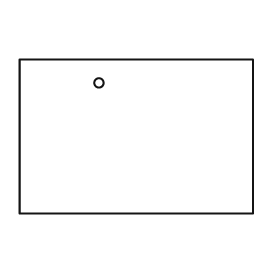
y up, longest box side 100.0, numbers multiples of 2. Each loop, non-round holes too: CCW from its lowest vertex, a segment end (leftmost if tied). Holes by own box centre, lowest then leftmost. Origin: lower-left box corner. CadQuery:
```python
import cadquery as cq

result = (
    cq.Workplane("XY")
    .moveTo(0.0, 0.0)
    .lineTo(100.0, 0.0)
    .lineTo(100.0, 66.0)
    .lineTo(0.0, 66.0)
    .close()
    .moveTo(34.0, 56.0)
    .circle(2.0)
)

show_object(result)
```